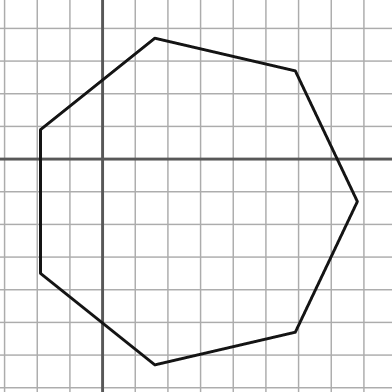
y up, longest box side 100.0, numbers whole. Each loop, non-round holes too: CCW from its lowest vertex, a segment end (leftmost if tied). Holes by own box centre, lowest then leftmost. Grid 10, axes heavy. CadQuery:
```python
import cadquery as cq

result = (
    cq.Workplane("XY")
    .moveTo(16.0, -63.0)
    .lineTo(59.0, -53.0)
    .lineTo(78.0, -13.0)
    .lineTo(59.0, 27.0)
    .lineTo(16.0, 37.0)
    .lineTo(-19.0, 9.0)
    .lineTo(-19.0, -35.0)
    .close()
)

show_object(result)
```